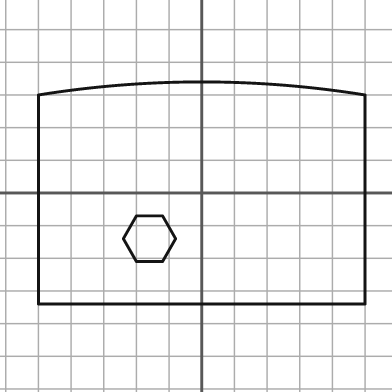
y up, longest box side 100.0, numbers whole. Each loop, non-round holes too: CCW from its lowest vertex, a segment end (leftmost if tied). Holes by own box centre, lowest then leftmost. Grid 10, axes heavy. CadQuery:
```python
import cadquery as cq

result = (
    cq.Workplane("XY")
    .moveTo(-50.0, -34.0)
    .lineTo(50.0, -34.0)
    .lineTo(50.0, 30.0)
    .threePointArc((0.0, 34.0), (-50.0, 30.0))
    .close()
    .moveTo(-20.0, -21.0)
    .lineTo(-12.0, -21.0)
    .lineTo(-8.0, -14.0)
    .lineTo(-12.0, -7.0)
    .lineTo(-20.0, -7.0)
    .lineTo(-24.0, -14.0)
    .close()
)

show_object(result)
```